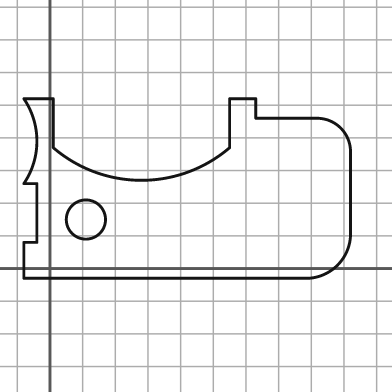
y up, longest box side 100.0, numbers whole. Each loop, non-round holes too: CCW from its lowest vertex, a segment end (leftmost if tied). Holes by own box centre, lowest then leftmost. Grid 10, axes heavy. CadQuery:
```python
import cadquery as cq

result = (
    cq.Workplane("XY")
    .moveTo(-8.0, -3.0)
    .lineTo(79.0, -3.0)
    .threePointArc((88.0, 1.0), (92.0, 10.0))
    .lineTo(92.0, 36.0)
    .threePointArc((89.0, 43.0), (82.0, 46.0))
    .lineTo(63.0, 46.0)
    .lineTo(63.0, 52.0)
    .lineTo(55.0, 52.0)
    .lineTo(55.0, 37.0)
    .threePointArc((28.0, 27.0), (1.0, 37.0))
    .lineTo(1.0, 52.0)
    .lineTo(-8.0, 52.0)
    .threePointArc((-4.0, 39.0), (-8.0, 26.0))
    .lineTo(-4.0, 26.0)
    .lineTo(-4.0, 8.0)
    .lineTo(-8.0, 8.0)
    .close()
    .moveTo(11.0, 15.0)
    .circle(6.0)
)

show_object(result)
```